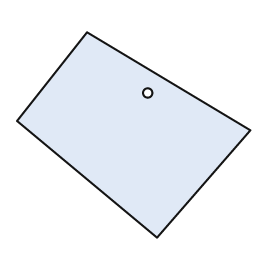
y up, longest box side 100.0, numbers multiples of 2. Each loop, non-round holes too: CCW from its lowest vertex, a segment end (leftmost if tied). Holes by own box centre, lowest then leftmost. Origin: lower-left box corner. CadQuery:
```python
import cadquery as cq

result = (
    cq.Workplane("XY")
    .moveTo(60.0, 0.0)
    .lineTo(100.0, 46.0)
    .lineTo(30.0, 88.0)
    .lineTo(0.0, 50.0)
    .close()
    .moveTo(56.0, 62.0)
    .circle(2.0)
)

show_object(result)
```